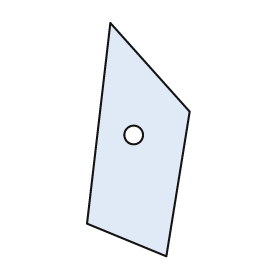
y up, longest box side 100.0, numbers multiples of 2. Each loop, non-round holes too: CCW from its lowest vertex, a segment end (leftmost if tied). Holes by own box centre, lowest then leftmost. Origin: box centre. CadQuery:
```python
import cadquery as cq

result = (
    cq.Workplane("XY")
    .moveTo(12.0, -50.0)
    .lineTo(22.0, 12.0)
    .lineTo(-12.0, 50.0)
    .lineTo(-22.0, -36.0)
    .close()
    .moveTo(-2.0, 2.0)
    .circle(4.0)
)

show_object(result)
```